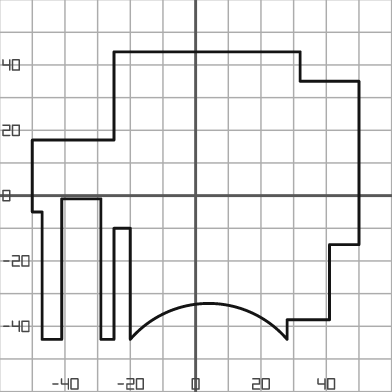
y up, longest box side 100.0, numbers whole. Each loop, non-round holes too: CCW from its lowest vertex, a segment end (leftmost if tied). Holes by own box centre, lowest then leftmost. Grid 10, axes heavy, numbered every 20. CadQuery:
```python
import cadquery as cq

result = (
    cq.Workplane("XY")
    .moveTo(-47.0, -44.0)
    .lineTo(-41.0, -44.0)
    .lineTo(-41.0, -1.0)
    .lineTo(-29.0, -1.0)
    .lineTo(-29.0, -44.0)
    .lineTo(-25.0, -44.0)
    .lineTo(-25.0, -10.0)
    .lineTo(-20.0, -10.0)
    .lineTo(-20.0, -44.0)
    .threePointArc((4.0, -33.0), (28.0, -44.0))
    .lineTo(28.0, -38.0)
    .lineTo(41.0, -38.0)
    .lineTo(41.0, -15.0)
    .lineTo(50.0, -15.0)
    .lineTo(50.0, 35.0)
    .lineTo(32.0, 35.0)
    .lineTo(32.0, 44.0)
    .lineTo(-25.0, 44.0)
    .lineTo(-25.0, 17.0)
    .lineTo(-50.0, 17.0)
    .lineTo(-50.0, -5.0)
    .lineTo(-47.0, -5.0)
    .close()
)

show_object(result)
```